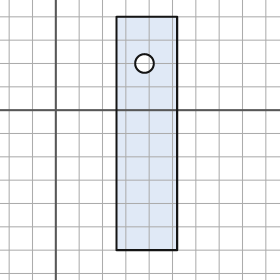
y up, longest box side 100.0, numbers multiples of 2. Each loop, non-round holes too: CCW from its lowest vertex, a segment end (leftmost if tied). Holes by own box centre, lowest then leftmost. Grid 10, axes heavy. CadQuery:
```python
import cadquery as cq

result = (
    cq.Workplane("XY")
    .moveTo(26.0, -60.0)
    .lineTo(52.0, -60.0)
    .lineTo(52.0, 40.0)
    .lineTo(26.0, 40.0)
    .close()
    .moveTo(38.0, 20.0)
    .circle(4.0)
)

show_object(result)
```